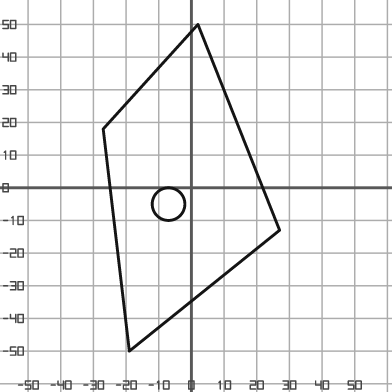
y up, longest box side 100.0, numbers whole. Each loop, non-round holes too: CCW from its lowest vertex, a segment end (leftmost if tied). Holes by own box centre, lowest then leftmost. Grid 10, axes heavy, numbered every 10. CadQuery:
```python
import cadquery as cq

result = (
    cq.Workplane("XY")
    .moveTo(-19.0, -50.0)
    .lineTo(27.0, -13.0)
    .lineTo(2.0, 50.0)
    .lineTo(-27.0, 18.0)
    .close()
    .moveTo(-7.0, -5.0)
    .circle(5.0)
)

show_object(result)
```